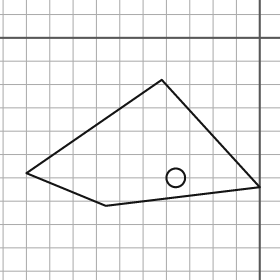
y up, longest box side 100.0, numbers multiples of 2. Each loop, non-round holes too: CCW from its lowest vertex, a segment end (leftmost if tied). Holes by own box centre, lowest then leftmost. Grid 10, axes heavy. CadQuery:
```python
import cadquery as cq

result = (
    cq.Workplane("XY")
    .moveTo(-66.0, -72.0)
    .lineTo(0.0, -64.0)
    .lineTo(-42.0, -18.0)
    .lineTo(-100.0, -58.0)
    .close()
    .moveTo(-36.0, -60.0)
    .circle(4.0)
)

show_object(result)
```